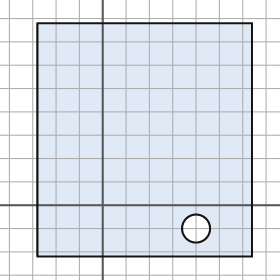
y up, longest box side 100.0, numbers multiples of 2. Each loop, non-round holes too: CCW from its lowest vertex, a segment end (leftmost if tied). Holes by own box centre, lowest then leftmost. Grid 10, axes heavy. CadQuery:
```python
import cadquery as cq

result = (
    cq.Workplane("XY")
    .moveTo(-28.0, -22.0)
    .lineTo(64.0, -22.0)
    .lineTo(64.0, 78.0)
    .lineTo(-28.0, 78.0)
    .close()
    .moveTo(40.0, -10.0)
    .circle(6.0)
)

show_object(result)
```